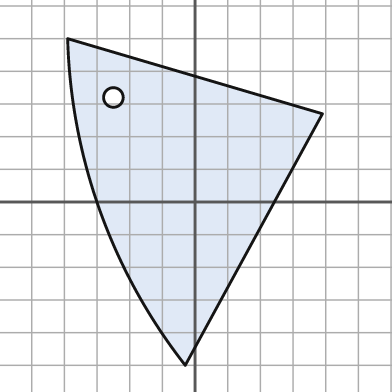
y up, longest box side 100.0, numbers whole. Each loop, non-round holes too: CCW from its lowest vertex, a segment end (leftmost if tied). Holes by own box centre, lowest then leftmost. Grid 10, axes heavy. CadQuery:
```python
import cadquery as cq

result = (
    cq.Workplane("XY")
    .moveTo(-3.0, -50.0)
    .lineTo(39.0, 27.0)
    .lineTo(-39.0, 50.0)
    .threePointArc((-29.0, -3.0), (-3.0, -50.0))
    .close()
    .moveTo(-25.0, 32.0)
    .circle(3.0)
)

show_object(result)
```